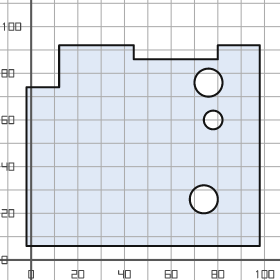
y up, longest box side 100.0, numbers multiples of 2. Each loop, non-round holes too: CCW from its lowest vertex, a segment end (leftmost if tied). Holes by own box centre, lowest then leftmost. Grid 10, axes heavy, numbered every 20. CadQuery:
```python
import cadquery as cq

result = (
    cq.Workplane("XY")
    .moveTo(-2.0, 6.0)
    .lineTo(98.0, 6.0)
    .lineTo(98.0, 92.0)
    .lineTo(80.0, 92.0)
    .lineTo(80.0, 86.0)
    .lineTo(44.0, 86.0)
    .lineTo(44.0, 92.0)
    .lineTo(12.0, 92.0)
    .lineTo(12.0, 74.0)
    .lineTo(-2.0, 74.0)
    .close()
    .moveTo(74.0, 26.0)
    .circle(6.0)
    .moveTo(78.0, 60.0)
    .circle(4.0)
    .moveTo(76.0, 76.0)
    .circle(6.0)
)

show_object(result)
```